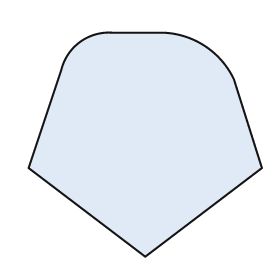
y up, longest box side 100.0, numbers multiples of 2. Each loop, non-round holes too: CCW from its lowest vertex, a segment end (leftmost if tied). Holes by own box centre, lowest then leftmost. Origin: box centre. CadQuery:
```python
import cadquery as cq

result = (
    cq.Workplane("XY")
    .moveTo(0.0, -48.0)
    .lineTo(50.0, -10.0)
    .lineTo(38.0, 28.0)
    .threePointArc((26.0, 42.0), (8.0, 48.0))
    .lineTo(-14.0, 48.0)
    .threePointArc((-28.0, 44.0), (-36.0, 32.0))
    .lineTo(-50.0, -10.0)
    .close()
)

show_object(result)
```